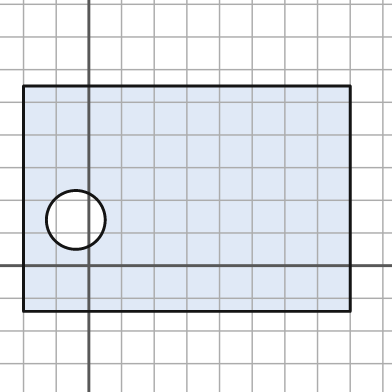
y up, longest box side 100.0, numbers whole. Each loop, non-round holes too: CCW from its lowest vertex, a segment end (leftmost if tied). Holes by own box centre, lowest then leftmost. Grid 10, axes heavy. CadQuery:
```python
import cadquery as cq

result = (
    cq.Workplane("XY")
    .moveTo(-20.0, -14.0)
    .lineTo(80.0, -14.0)
    .lineTo(80.0, 55.0)
    .lineTo(-20.0, 55.0)
    .close()
    .moveTo(-4.0, 14.0)
    .circle(9.0)
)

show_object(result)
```